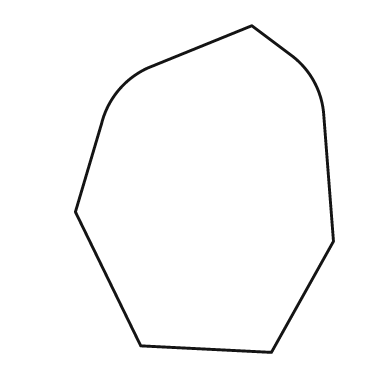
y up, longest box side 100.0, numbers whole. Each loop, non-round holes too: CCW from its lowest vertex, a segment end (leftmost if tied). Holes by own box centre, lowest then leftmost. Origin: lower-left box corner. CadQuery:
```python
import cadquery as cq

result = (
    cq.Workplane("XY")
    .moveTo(60.0, 0.0)
    .lineTo(79.0, 34.0)
    .lineTo(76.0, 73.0)
    .threePointArc((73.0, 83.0), (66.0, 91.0))
    .lineTo(54.0, 100.0)
    .lineTo(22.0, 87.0)
    .threePointArc((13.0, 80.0), (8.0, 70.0))
    .lineTo(0.0, 43.0)
    .lineTo(20.0, 2.0)
    .close()
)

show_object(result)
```